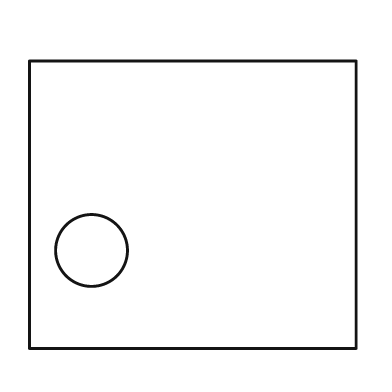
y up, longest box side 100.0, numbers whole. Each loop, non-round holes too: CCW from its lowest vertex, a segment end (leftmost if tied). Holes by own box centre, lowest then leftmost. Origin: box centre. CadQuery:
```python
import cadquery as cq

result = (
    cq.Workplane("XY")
    .moveTo(-50.0, -44.0)
    .lineTo(50.0, -44.0)
    .lineTo(50.0, 44.0)
    .lineTo(-50.0, 44.0)
    .close()
    .moveTo(-31.0, -14.0)
    .circle(11.0)
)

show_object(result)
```